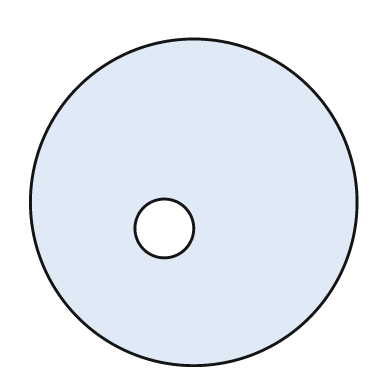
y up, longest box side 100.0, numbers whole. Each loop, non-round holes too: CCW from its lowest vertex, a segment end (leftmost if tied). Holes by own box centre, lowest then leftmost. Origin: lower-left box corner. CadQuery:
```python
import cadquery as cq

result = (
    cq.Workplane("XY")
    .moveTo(50.0, 50.0)
    .circle(50.0)
    .moveTo(41.0, 42.0)
    .circle(9.0)
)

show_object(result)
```